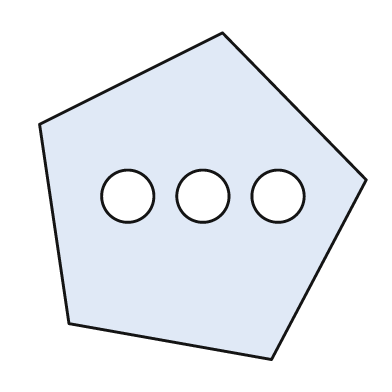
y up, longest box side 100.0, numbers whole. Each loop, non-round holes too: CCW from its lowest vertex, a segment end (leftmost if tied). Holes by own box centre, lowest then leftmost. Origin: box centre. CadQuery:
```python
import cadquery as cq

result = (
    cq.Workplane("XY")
    .moveTo(21.0, -50.0)
    .lineTo(50.0, 5.0)
    .lineTo(6.0, 50.0)
    .lineTo(-50.0, 22.0)
    .lineTo(-41.0, -39.0)
    .close()
    .moveTo(-23.0, 0.0)
    .circle(8.0)
    .moveTo(0.0, 0.0)
    .circle(8.0)
    .moveTo(23.0, 0.0)
    .circle(8.0)
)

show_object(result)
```